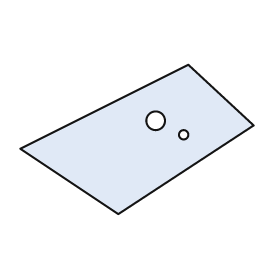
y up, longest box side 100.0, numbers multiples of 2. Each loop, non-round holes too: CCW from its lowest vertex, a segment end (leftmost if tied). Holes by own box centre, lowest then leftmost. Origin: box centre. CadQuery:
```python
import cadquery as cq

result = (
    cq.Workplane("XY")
    .moveTo(-8.0, -32.0)
    .lineTo(50.0, 6.0)
    .lineTo(22.0, 32.0)
    .lineTo(-50.0, -4.0)
    .close()
    .moveTo(20.0, 2.0)
    .circle(2.0)
    .moveTo(8.0, 8.0)
    .circle(4.0)
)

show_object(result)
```